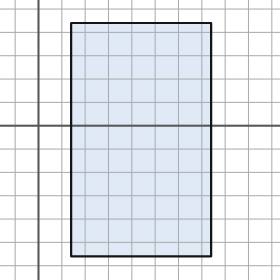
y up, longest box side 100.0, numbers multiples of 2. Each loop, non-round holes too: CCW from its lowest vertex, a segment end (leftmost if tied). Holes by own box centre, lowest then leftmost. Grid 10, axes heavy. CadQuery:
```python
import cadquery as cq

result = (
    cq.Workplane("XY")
    .moveTo(14.0, -56.0)
    .lineTo(74.0, -56.0)
    .lineTo(74.0, 44.0)
    .lineTo(14.0, 44.0)
    .close()
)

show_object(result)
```